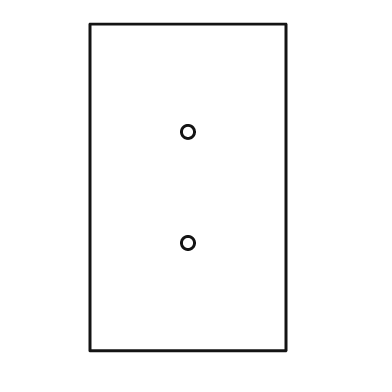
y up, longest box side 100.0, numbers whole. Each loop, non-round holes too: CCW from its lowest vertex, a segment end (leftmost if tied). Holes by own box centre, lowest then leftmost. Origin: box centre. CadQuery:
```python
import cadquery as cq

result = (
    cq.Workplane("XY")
    .moveTo(-30.0, -50.0)
    .lineTo(30.0, -50.0)
    .lineTo(30.0, 50.0)
    .lineTo(-30.0, 50.0)
    .close()
    .moveTo(0.0, -17.0)
    .circle(2.0)
    .moveTo(0.0, 17.0)
    .circle(2.0)
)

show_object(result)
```